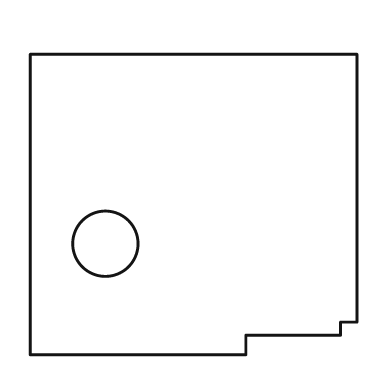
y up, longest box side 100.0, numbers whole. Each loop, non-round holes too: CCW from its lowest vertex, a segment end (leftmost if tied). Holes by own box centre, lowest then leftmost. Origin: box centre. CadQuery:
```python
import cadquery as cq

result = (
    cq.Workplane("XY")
    .moveTo(-50.0, -46.0)
    .lineTo(16.0, -46.0)
    .lineTo(16.0, -40.0)
    .lineTo(45.0, -40.0)
    .lineTo(45.0, -36.0)
    .lineTo(50.0, -36.0)
    .lineTo(50.0, 46.0)
    .lineTo(-50.0, 46.0)
    .close()
    .moveTo(-27.0, -12.0)
    .circle(10.0)
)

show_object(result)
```